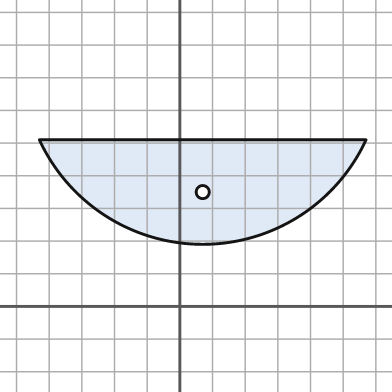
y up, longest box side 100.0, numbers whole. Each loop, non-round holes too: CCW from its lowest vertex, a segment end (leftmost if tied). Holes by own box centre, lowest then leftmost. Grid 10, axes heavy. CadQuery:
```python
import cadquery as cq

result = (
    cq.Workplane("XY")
    .moveTo(-43.0, 51.0)
    .threePointArc((7.0, 19.0), (57.0, 51.0))
    .close()
    .moveTo(7.0, 35.0)
    .circle(2.0)
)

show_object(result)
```